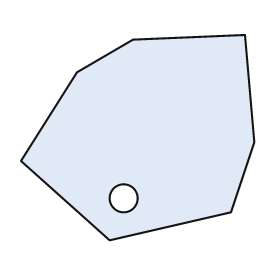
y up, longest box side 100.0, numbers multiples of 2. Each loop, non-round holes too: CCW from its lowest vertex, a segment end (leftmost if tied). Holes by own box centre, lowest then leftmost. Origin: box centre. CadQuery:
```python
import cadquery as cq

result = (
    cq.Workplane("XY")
    .moveTo(-12.0, -44.0)
    .lineTo(40.0, -32.0)
    .lineTo(50.0, -2.0)
    .lineTo(46.0, 44.0)
    .lineTo(-2.0, 42.0)
    .lineTo(-26.0, 28.0)
    .lineTo(-50.0, -10.0)
    .close()
    .moveTo(-6.0, -26.0)
    .circle(6.0)
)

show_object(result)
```